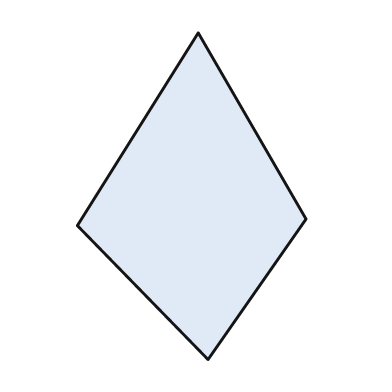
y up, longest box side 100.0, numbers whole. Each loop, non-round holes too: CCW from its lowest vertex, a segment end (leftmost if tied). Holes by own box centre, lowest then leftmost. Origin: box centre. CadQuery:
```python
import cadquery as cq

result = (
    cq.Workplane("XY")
    .moveTo(5.0, -50.0)
    .lineTo(35.0, -7.0)
    .lineTo(2.0, 50.0)
    .lineTo(-35.0, -9.0)
    .close()
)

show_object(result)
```